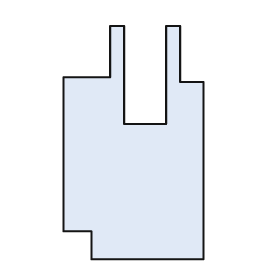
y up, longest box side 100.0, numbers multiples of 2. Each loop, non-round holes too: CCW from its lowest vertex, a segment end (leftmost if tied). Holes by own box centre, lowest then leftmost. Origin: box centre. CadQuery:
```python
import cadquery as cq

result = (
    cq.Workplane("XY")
    .moveTo(-18.0, -50.0)
    .lineTo(30.0, -50.0)
    .lineTo(30.0, 26.0)
    .lineTo(20.0, 26.0)
    .lineTo(20.0, 50.0)
    .lineTo(14.0, 50.0)
    .lineTo(14.0, 8.0)
    .lineTo(-4.0, 8.0)
    .lineTo(-4.0, 50.0)
    .lineTo(-10.0, 50.0)
    .lineTo(-10.0, 28.0)
    .lineTo(-30.0, 28.0)
    .lineTo(-30.0, -38.0)
    .lineTo(-18.0, -38.0)
    .close()
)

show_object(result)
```